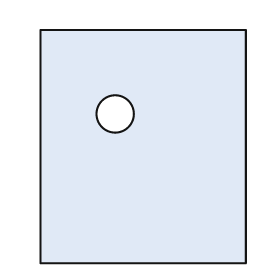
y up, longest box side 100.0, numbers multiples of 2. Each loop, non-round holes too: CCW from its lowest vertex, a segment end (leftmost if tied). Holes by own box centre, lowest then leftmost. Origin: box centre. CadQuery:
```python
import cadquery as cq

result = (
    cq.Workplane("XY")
    .moveTo(-44.0, -50.0)
    .lineTo(44.0, -50.0)
    .lineTo(44.0, 50.0)
    .lineTo(-44.0, 50.0)
    .close()
    .moveTo(-12.0, 14.0)
    .circle(8.0)
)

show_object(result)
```